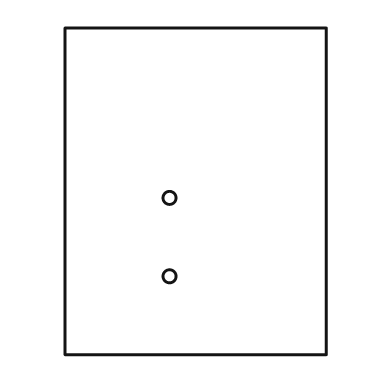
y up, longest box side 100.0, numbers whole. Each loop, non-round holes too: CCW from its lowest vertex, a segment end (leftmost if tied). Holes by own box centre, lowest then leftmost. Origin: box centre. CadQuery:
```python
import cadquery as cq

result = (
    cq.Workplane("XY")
    .moveTo(-40.0, -50.0)
    .lineTo(40.0, -50.0)
    .lineTo(40.0, 50.0)
    .lineTo(-40.0, 50.0)
    .close()
    .moveTo(-8.0, -26.0)
    .circle(2.0)
    .moveTo(-8.0, -2.0)
    .circle(2.0)
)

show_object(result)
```